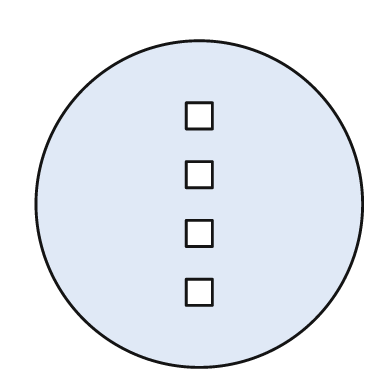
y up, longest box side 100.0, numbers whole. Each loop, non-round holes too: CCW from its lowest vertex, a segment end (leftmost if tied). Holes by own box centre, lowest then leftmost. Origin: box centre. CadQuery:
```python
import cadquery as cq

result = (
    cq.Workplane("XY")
    .moveTo(0.0, 0.0)
    .circle(50.0)
    .moveTo(-4.0, -31.0)
    .lineTo(4.0, -31.0)
    .lineTo(4.0, -23.0)
    .lineTo(-4.0, -23.0)
    .close()
    .moveTo(-4.0, -13.0)
    .lineTo(4.0, -13.0)
    .lineTo(4.0, -5.0)
    .lineTo(-4.0, -5.0)
    .close()
    .moveTo(-4.0, 5.0)
    .lineTo(4.0, 5.0)
    .lineTo(4.0, 13.0)
    .lineTo(-4.0, 13.0)
    .close()
    .moveTo(-4.0, 23.0)
    .lineTo(4.0, 23.0)
    .lineTo(4.0, 31.0)
    .lineTo(-4.0, 31.0)
    .close()
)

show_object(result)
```